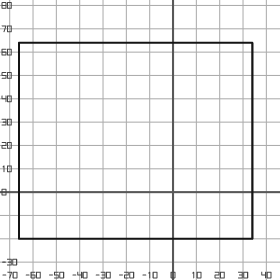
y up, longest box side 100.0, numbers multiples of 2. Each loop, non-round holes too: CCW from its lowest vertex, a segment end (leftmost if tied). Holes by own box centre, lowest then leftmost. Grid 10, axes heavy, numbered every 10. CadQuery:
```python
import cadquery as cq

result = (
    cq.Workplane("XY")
    .moveTo(-66.0, -20.0)
    .lineTo(34.0, -20.0)
    .lineTo(34.0, 64.0)
    .lineTo(-66.0, 64.0)
    .close()
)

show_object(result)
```